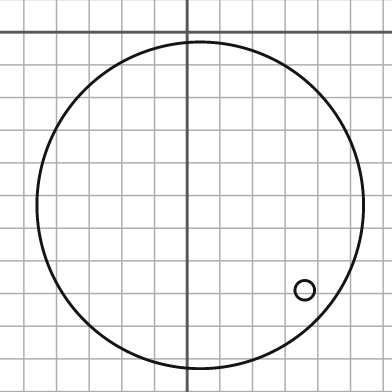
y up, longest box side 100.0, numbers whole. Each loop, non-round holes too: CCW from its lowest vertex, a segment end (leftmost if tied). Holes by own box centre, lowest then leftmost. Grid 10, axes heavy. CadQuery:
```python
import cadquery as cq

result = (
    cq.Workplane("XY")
    .moveTo(4.0, -53.0)
    .circle(50.0)
    .moveTo(36.0, -79.0)
    .circle(3.0)
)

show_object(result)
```